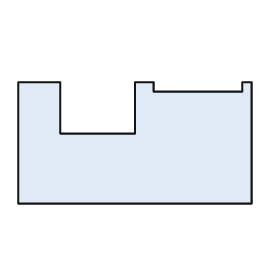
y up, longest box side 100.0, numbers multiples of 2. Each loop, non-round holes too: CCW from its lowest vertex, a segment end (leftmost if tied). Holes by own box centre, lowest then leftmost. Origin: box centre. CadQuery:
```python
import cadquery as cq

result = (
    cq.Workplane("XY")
    .moveTo(-50.0, -26.0)
    .lineTo(50.0, -26.0)
    .lineTo(50.0, 26.0)
    .lineTo(46.0, 26.0)
    .lineTo(46.0, 22.0)
    .lineTo(8.0, 22.0)
    .lineTo(8.0, 26.0)
    .lineTo(0.0, 26.0)
    .lineTo(0.0, 4.0)
    .lineTo(-32.0, 4.0)
    .lineTo(-32.0, 26.0)
    .lineTo(-50.0, 26.0)
    .close()
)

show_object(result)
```